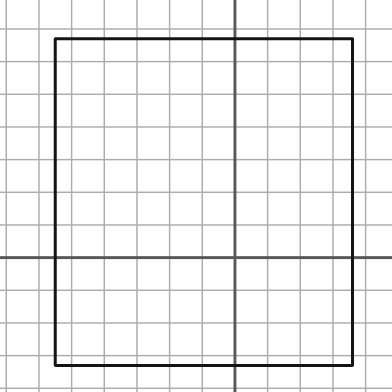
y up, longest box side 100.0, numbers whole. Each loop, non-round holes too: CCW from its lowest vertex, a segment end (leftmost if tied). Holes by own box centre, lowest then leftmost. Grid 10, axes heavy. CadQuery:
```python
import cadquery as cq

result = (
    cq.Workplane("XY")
    .moveTo(-55.0, -33.0)
    .lineTo(36.0, -33.0)
    .lineTo(36.0, 67.0)
    .lineTo(-55.0, 67.0)
    .close()
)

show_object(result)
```